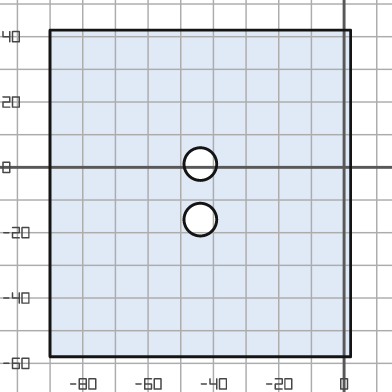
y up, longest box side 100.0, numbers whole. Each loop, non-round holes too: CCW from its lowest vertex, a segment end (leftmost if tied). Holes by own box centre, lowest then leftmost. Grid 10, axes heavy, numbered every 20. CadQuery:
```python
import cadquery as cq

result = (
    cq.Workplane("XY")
    .moveTo(-90.0, -58.0)
    .lineTo(2.0, -58.0)
    .lineTo(2.0, 42.0)
    .lineTo(-90.0, 42.0)
    .close()
    .moveTo(-44.0, -16.0)
    .circle(5.0)
    .moveTo(-44.0, 1.0)
    .circle(5.0)
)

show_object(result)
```